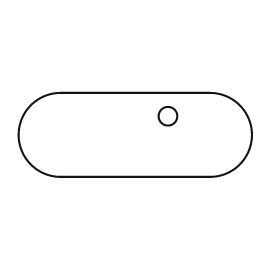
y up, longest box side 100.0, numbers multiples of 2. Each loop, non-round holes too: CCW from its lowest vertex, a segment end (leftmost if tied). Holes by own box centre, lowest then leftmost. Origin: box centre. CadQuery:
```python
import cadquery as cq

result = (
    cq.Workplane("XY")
    .moveTo(-32.0, -18.0)
    .lineTo(32.0, -18.0)
    .threePointArc((50.0, 0.0), (32.0, 18.0))
    .lineTo(-32.0, 18.0)
    .threePointArc((-50.0, 0.0), (-32.0, -18.0))
    .close()
    .moveTo(14.0, 8.0)
    .circle(4.0)
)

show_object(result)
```